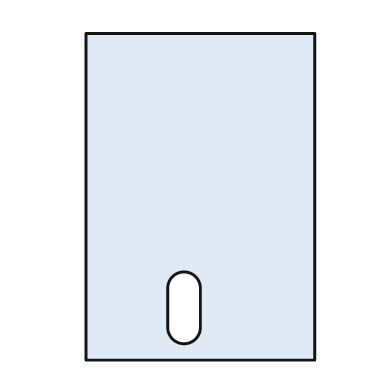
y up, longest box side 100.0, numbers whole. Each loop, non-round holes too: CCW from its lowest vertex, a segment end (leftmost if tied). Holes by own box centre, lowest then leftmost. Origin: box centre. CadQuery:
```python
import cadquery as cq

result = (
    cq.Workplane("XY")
    .moveTo(-35.0, -50.0)
    .lineTo(35.0, -50.0)
    .lineTo(35.0, 50.0)
    .lineTo(-35.0, 50.0)
    .close()
    .moveTo(-10.0, -40.0)
    .threePointArc((-5.0, -45.0), (0.0, -40.0))
    .lineTo(0.0, -28.0)
    .threePointArc((-5.0, -23.0), (-10.0, -28.0))
    .close()
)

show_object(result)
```